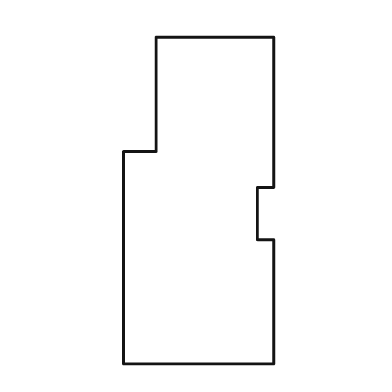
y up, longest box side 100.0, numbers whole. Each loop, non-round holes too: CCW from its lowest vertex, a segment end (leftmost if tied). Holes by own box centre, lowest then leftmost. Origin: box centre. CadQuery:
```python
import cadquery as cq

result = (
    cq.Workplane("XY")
    .moveTo(-23.0, -50.0)
    .lineTo(23.0, -50.0)
    .lineTo(23.0, -12.0)
    .lineTo(18.0, -12.0)
    .lineTo(18.0, 4.0)
    .lineTo(23.0, 4.0)
    .lineTo(23.0, 50.0)
    .lineTo(-13.0, 50.0)
    .lineTo(-13.0, 15.0)
    .lineTo(-23.0, 15.0)
    .close()
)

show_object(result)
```